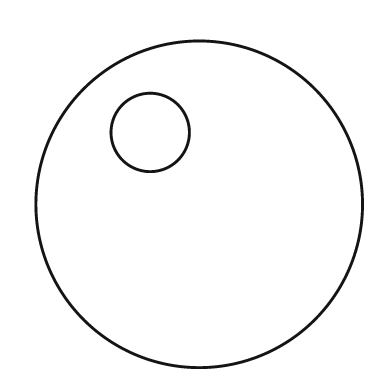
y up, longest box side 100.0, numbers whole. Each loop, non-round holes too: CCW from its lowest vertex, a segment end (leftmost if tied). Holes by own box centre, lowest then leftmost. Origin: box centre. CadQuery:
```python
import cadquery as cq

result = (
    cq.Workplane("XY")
    .moveTo(0.0, 0.0)
    .circle(50.0)
    .moveTo(-15.0, 22.0)
    .circle(12.0)
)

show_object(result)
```